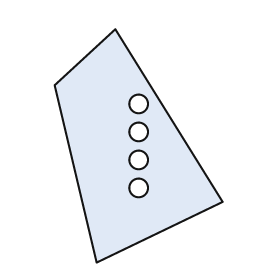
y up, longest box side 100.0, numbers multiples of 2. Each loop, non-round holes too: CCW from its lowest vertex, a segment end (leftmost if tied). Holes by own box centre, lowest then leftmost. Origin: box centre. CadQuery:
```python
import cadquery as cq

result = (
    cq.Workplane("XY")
    .moveTo(-18.0, -50.0)
    .lineTo(36.0, -24.0)
    .lineTo(-10.0, 50.0)
    .lineTo(-36.0, 26.0)
    .close()
    .moveTo(0.0, -18.0)
    .circle(4.0)
    .moveTo(0.0, -6.0)
    .circle(4.0)
    .moveTo(0.0, 6.0)
    .circle(4.0)
    .moveTo(0.0, 18.0)
    .circle(4.0)
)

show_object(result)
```